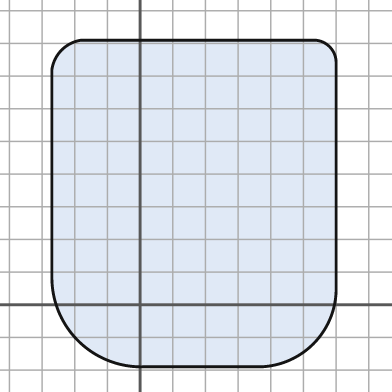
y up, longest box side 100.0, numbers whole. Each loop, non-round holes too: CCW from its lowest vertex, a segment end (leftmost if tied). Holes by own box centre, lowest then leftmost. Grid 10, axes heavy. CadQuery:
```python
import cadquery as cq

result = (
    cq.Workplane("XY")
    .moveTo(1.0, -19.0)
    .lineTo(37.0, -19.0)
    .threePointArc((53.0, -12.0), (60.0, 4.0))
    .lineTo(60.0, 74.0)
    .threePointArc((58.0, 79.0), (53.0, 81.0))
    .lineTo(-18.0, 81.0)
    .threePointArc((-24.0, 78.0), (-27.0, 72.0))
    .lineTo(-27.0, 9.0)
    .threePointArc((-19.0, -11.0), (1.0, -19.0))
    .close()
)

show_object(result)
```